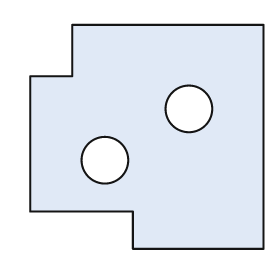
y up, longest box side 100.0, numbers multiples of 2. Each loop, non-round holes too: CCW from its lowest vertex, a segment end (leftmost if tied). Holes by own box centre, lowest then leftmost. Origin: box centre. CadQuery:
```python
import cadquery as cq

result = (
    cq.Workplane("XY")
    .moveTo(-6.0, -48.0)
    .lineTo(50.0, -48.0)
    .lineTo(50.0, 48.0)
    .lineTo(-32.0, 48.0)
    .lineTo(-32.0, 26.0)
    .lineTo(-50.0, 26.0)
    .lineTo(-50.0, -32.0)
    .lineTo(-6.0, -32.0)
    .close()
    .moveTo(-18.0, -10.0)
    .circle(10.0)
    .moveTo(18.0, 12.0)
    .circle(10.0)
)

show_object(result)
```